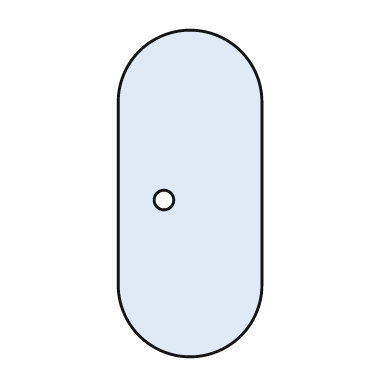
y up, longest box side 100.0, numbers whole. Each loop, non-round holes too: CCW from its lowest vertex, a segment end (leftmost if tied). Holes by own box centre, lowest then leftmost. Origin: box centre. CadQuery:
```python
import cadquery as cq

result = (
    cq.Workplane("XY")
    .moveTo(-22.0, -28.0)
    .threePointArc((0.0, -50.0), (22.0, -28.0))
    .lineTo(22.0, 28.0)
    .threePointArc((0.0, 50.0), (-22.0, 28.0))
    .close()
    .moveTo(-8.0, -2.0)
    .circle(3.0)
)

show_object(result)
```